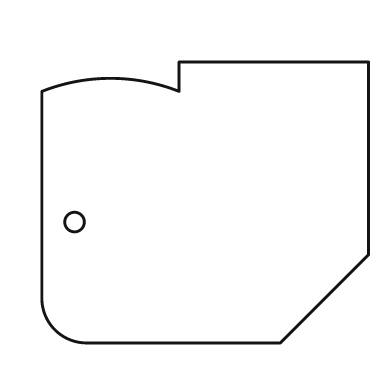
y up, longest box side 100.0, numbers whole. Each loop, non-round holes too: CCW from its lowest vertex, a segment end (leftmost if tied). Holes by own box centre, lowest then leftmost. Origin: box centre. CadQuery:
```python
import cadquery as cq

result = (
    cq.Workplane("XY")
    .moveTo(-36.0, -43.0)
    .lineTo(23.0, -43.0)
    .lineTo(50.0, -16.0)
    .lineTo(50.0, 43.0)
    .lineTo(-8.0, 43.0)
    .lineTo(-8.0, 34.0)
    .threePointArc((-29.0, 38.0), (-50.0, 34.0))
    .lineTo(-50.0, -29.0)
    .threePointArc((-46.0, -39.0), (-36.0, -43.0))
    .close()
    .moveTo(-40.0, -6.0)
    .circle(3.0)
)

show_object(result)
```